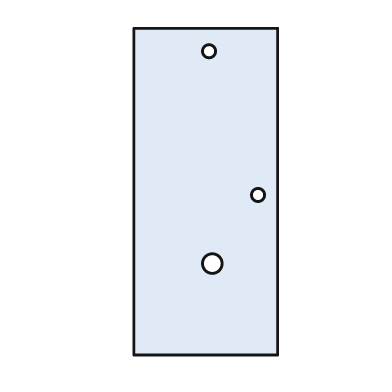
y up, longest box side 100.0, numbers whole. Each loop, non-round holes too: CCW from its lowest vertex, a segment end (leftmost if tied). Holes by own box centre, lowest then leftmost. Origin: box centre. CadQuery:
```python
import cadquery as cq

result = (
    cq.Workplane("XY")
    .moveTo(-22.0, -50.0)
    .lineTo(22.0, -50.0)
    .lineTo(22.0, 50.0)
    .lineTo(-22.0, 50.0)
    .close()
    .moveTo(2.0, -22.0)
    .circle(3.0)
    .moveTo(16.0, -1.0)
    .circle(2.0)
    .moveTo(1.0, 43.0)
    .circle(2.0)
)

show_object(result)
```